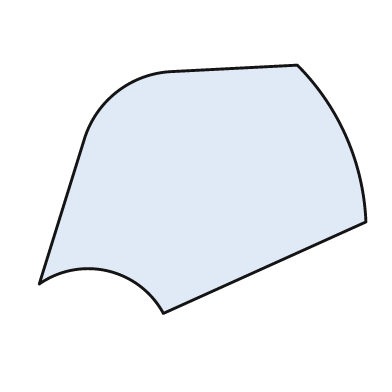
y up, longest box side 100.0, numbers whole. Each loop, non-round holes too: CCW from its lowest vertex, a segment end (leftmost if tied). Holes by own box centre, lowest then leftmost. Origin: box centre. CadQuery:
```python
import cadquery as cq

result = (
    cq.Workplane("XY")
    .moveTo(-12.0, -38.0)
    .lineTo(50.0, -10.0)
    .threePointArc((44.0, 16.0), (29.0, 38.0))
    .lineTo(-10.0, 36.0)
    .threePointArc((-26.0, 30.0), (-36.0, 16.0))
    .lineTo(-50.0, -29.0)
    .threePointArc((-29.0, -25.0), (-12.0, -38.0))
    .close()
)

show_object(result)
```